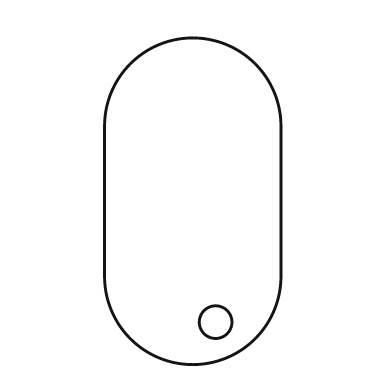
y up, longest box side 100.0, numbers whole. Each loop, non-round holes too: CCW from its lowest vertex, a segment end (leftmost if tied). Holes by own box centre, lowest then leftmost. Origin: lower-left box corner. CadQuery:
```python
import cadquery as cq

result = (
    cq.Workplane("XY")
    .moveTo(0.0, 27.0)
    .threePointArc((27.0, 0.0), (54.0, 27.0))
    .lineTo(54.0, 73.0)
    .threePointArc((27.0, 100.0), (0.0, 73.0))
    .close()
    .moveTo(34.0, 13.0)
    .circle(5.0)
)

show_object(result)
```